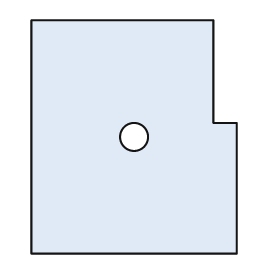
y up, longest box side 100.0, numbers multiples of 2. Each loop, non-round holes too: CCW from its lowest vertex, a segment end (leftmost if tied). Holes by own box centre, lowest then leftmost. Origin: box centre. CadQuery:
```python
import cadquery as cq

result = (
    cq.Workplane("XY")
    .moveTo(-44.0, -50.0)
    .lineTo(44.0, -50.0)
    .lineTo(44.0, 6.0)
    .lineTo(34.0, 6.0)
    .lineTo(34.0, 50.0)
    .lineTo(-44.0, 50.0)
    .close()
    .moveTo(0.0, 0.0)
    .circle(6.0)
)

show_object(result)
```